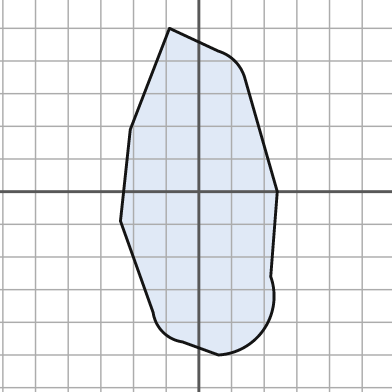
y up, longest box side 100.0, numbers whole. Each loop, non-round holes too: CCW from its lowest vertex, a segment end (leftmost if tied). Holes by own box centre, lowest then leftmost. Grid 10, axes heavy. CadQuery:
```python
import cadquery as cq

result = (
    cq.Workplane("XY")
    .moveTo(6.0, -50.0)
    .threePointArc((20.0, -42.0), (22.0, -26.0))
    .lineTo(24.0, 0.0)
    .lineTo(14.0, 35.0)
    .threePointArc((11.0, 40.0), (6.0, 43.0))
    .lineTo(-9.0, 50.0)
    .lineTo(-21.0, 19.0)
    .lineTo(-24.0, -9.0)
    .lineTo(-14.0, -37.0)
    .threePointArc((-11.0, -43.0), (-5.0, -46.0))
    .close()
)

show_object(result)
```